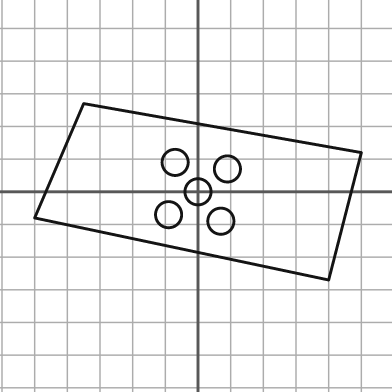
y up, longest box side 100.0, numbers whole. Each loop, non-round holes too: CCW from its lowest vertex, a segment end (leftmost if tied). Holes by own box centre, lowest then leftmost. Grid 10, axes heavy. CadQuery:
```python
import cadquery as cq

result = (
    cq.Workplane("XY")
    .moveTo(40.0, -27.0)
    .lineTo(50.0, 12.0)
    .lineTo(-35.0, 27.0)
    .lineTo(-50.0, -8.0)
    .close()
    .moveTo(7.0, -9.0)
    .circle(4.0)
    .moveTo(-9.0, -7.0)
    .circle(4.0)
    .moveTo(0.0, 0.0)
    .circle(4.0)
    .moveTo(9.0, 7.0)
    .circle(4.0)
    .moveTo(-7.0, 9.0)
    .circle(4.0)
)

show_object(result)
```